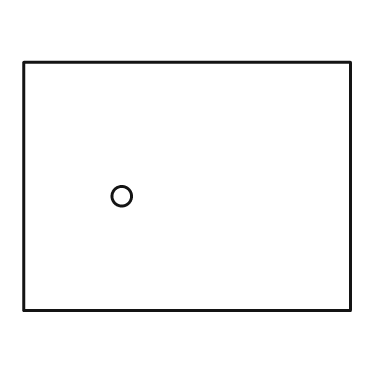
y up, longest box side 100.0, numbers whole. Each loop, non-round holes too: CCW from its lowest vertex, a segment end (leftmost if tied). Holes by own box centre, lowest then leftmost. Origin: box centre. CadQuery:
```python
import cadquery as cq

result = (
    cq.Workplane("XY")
    .moveTo(-50.0, -38.0)
    .lineTo(50.0, -38.0)
    .lineTo(50.0, 38.0)
    .lineTo(-50.0, 38.0)
    .close()
    .moveTo(-20.0, -3.0)
    .circle(3.0)
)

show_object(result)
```